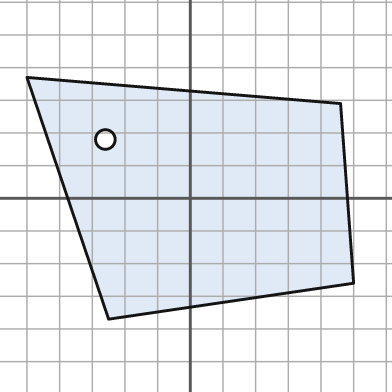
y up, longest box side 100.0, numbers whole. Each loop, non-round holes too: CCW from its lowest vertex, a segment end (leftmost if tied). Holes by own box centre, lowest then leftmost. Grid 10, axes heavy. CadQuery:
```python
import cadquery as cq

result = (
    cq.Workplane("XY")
    .moveTo(-25.0, -37.0)
    .lineTo(50.0, -26.0)
    .lineTo(46.0, 29.0)
    .lineTo(-50.0, 37.0)
    .close()
    .moveTo(-26.0, 18.0)
    .circle(3.0)
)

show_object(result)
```